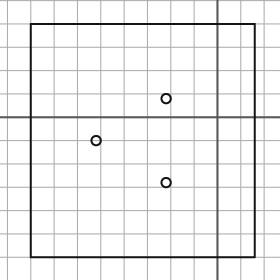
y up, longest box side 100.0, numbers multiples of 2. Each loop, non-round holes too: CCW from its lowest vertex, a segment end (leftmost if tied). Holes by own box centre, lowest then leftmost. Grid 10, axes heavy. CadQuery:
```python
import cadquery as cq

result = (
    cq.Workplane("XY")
    .moveTo(-80.0, -60.0)
    .lineTo(16.0, -60.0)
    .lineTo(16.0, 40.0)
    .lineTo(-80.0, 40.0)
    .close()
    .moveTo(-22.0, -28.0)
    .circle(2.0)
    .moveTo(-52.0, -10.0)
    .circle(2.0)
    .moveTo(-22.0, 8.0)
    .circle(2.0)
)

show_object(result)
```